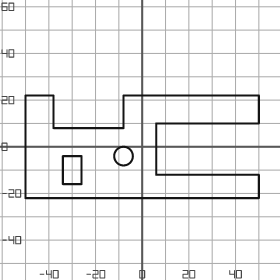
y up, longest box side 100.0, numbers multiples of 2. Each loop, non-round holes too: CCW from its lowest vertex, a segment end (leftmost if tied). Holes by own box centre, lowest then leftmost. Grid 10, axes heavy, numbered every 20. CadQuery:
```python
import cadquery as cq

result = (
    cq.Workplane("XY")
    .moveTo(-50.0, -22.0)
    .lineTo(50.0, -22.0)
    .lineTo(50.0, -12.0)
    .lineTo(6.0, -12.0)
    .lineTo(6.0, 10.0)
    .lineTo(50.0, 10.0)
    .lineTo(50.0, 22.0)
    .lineTo(-8.0, 22.0)
    .lineTo(-8.0, 8.0)
    .lineTo(-38.0, 8.0)
    .lineTo(-38.0, 22.0)
    .lineTo(-50.0, 22.0)
    .close()
    .moveTo(-34.0, -16.0)
    .lineTo(-26.0, -16.0)
    .lineTo(-26.0, -4.0)
    .lineTo(-34.0, -4.0)
    .close()
    .moveTo(-8.0, -4.0)
    .circle(4.0)
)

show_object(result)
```